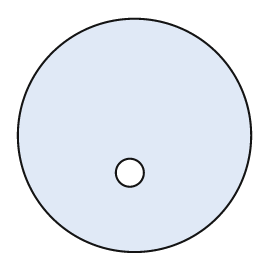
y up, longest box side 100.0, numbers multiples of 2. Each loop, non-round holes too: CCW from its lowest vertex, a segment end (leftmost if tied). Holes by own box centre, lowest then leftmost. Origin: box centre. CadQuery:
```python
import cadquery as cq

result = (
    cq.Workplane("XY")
    .moveTo(0.0, 0.0)
    .circle(50.0)
    .moveTo(-2.0, -16.0)
    .circle(6.0)
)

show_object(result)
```